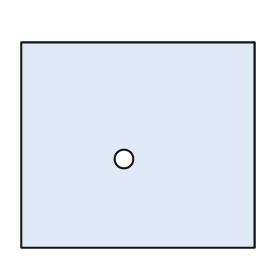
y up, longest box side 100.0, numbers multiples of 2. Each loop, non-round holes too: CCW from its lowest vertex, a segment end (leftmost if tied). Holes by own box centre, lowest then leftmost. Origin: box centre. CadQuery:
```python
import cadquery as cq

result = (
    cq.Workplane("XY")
    .moveTo(-50.0, -44.0)
    .lineTo(50.0, -44.0)
    .lineTo(50.0, 44.0)
    .lineTo(-50.0, 44.0)
    .close()
    .moveTo(-6.0, -6.0)
    .circle(4.0)
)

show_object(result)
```